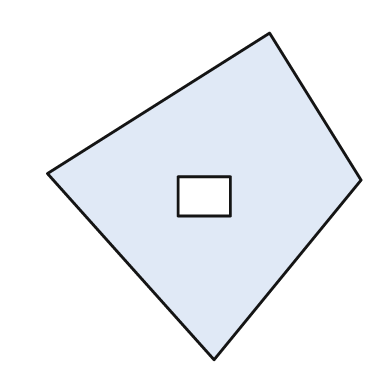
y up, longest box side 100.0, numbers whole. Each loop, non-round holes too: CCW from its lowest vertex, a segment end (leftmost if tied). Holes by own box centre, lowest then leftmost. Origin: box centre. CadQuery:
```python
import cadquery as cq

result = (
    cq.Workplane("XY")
    .moveTo(3.0, -50.0)
    .lineTo(48.0, 5.0)
    .lineTo(20.0, 50.0)
    .lineTo(-48.0, 7.0)
    .close()
    .moveTo(-8.0, -6.0)
    .lineTo(8.0, -6.0)
    .lineTo(8.0, 6.0)
    .lineTo(-8.0, 6.0)
    .close()
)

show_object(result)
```